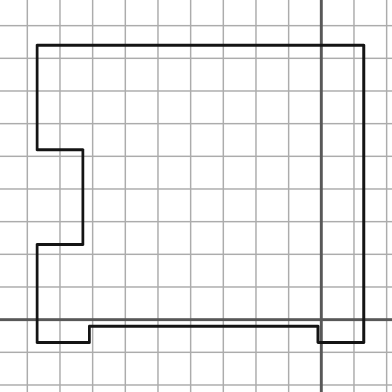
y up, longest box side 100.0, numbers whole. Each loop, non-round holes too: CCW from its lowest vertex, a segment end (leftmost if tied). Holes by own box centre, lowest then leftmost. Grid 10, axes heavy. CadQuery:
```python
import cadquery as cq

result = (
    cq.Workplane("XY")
    .moveTo(-87.0, -7.0)
    .lineTo(-71.0, -7.0)
    .lineTo(-71.0, -2.0)
    .lineTo(-1.0, -2.0)
    .lineTo(-1.0, -7.0)
    .lineTo(13.0, -7.0)
    .lineTo(13.0, 84.0)
    .lineTo(-87.0, 84.0)
    .lineTo(-87.0, 52.0)
    .lineTo(-73.0, 52.0)
    .lineTo(-73.0, 23.0)
    .lineTo(-87.0, 23.0)
    .close()
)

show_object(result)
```